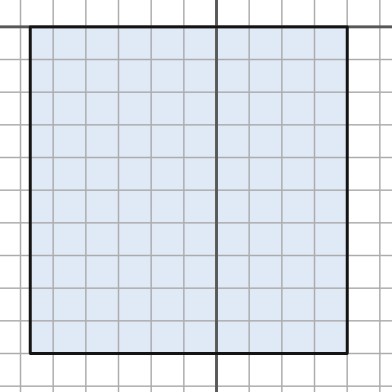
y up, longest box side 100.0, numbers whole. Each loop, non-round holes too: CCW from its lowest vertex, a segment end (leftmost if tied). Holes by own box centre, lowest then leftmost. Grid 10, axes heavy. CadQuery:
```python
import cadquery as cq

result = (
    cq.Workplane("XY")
    .moveTo(-57.0, -100.0)
    .lineTo(40.0, -100.0)
    .lineTo(40.0, 0.0)
    .lineTo(-57.0, 0.0)
    .close()
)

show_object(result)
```